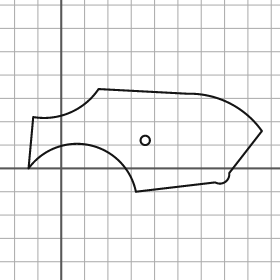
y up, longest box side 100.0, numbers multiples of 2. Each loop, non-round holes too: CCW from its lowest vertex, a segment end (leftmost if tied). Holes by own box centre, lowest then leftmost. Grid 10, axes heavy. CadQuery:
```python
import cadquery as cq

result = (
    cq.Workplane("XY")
    .moveTo(32.0, -10.0)
    .lineTo(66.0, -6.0)
    .threePointArc((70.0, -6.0), (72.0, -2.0))
    .lineTo(86.0, 16.0)
    .threePointArc((72.0, 28.0), (54.0, 32.0))
    .lineTo(16.0, 34.0)
    .threePointArc((4.0, 24.0), (-12.0, 22.0))
    .lineTo(-14.0, 0.0)
    .threePointArc((12.0, 10.0), (32.0, -10.0))
    .close()
    .moveTo(36.0, 12.0)
    .circle(2.0)
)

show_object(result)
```